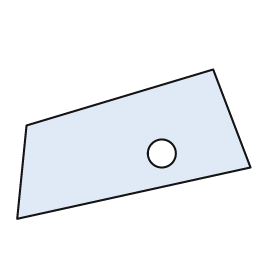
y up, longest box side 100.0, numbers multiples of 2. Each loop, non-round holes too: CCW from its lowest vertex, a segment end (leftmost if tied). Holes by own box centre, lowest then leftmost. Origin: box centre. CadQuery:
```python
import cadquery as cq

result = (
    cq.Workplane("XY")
    .moveTo(-50.0, -32.0)
    .lineTo(50.0, -10.0)
    .lineTo(34.0, 32.0)
    .lineTo(-46.0, 8.0)
    .close()
    .moveTo(12.0, -4.0)
    .circle(6.0)
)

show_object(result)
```